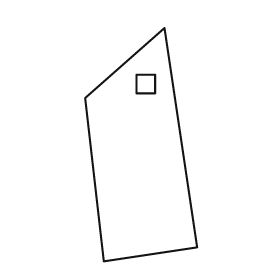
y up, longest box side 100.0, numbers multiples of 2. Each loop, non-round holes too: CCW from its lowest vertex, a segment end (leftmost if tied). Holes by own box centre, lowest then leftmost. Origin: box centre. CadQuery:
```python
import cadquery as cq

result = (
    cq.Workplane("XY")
    .moveTo(-16.0, -50.0)
    .lineTo(24.0, -44.0)
    .lineTo(10.0, 50.0)
    .lineTo(-24.0, 20.0)
    .close()
    .moveTo(-2.0, 22.0)
    .lineTo(6.0, 22.0)
    .lineTo(6.0, 30.0)
    .lineTo(-2.0, 30.0)
    .close()
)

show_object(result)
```